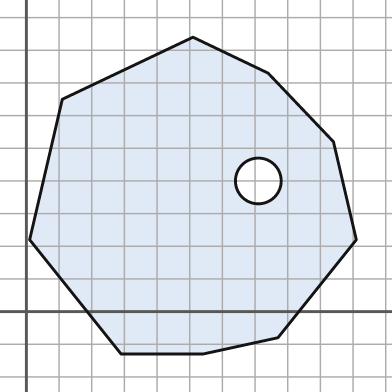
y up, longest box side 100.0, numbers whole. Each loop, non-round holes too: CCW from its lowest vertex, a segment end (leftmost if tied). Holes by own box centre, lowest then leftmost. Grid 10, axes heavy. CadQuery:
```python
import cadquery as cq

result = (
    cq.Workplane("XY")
    .moveTo(29.0, -13.0)
    .lineTo(54.0, -13.0)
    .lineTo(77.0, -8.0)
    .lineTo(101.0, 22.0)
    .lineTo(94.0, 52.0)
    .lineTo(74.0, 73.0)
    .lineTo(51.0, 84.0)
    .lineTo(11.0, 65.0)
    .lineTo(1.0, 22.0)
    .close()
    .moveTo(71.0, 40.0)
    .circle(7.0)
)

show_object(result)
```